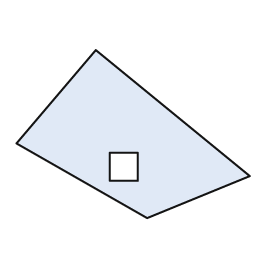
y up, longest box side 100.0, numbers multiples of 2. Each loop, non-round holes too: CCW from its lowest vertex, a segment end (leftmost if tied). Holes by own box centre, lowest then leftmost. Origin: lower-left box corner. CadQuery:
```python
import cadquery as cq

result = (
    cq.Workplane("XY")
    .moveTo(56.0, 0.0)
    .lineTo(100.0, 18.0)
    .lineTo(34.0, 72.0)
    .lineTo(0.0, 32.0)
    .close()
    .moveTo(40.0, 16.0)
    .lineTo(52.0, 16.0)
    .lineTo(52.0, 28.0)
    .lineTo(40.0, 28.0)
    .close()
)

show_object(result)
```